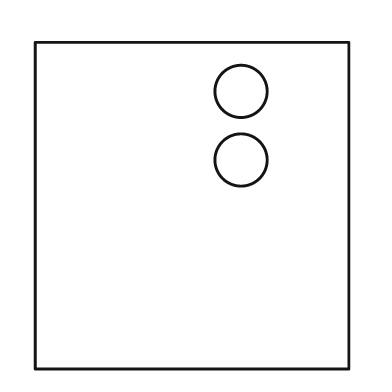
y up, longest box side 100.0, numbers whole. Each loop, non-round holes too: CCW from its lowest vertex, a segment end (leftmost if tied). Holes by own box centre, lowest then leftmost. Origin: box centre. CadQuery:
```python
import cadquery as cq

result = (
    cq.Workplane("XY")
    .moveTo(-48.0, -50.0)
    .lineTo(48.0, -50.0)
    .lineTo(48.0, 50.0)
    .lineTo(-48.0, 50.0)
    .close()
    .moveTo(15.0, 14.0)
    .circle(8.0)
    .moveTo(15.0, 35.0)
    .circle(8.0)
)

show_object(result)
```